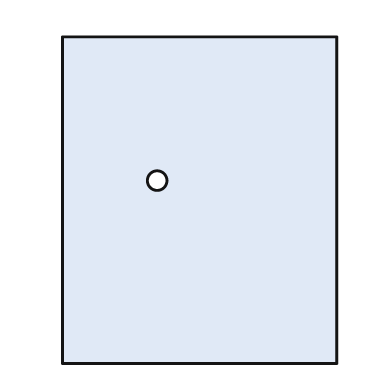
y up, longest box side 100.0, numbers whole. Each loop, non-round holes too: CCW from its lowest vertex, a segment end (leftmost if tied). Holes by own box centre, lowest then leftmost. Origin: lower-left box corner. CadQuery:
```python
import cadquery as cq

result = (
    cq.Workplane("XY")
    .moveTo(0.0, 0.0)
    .lineTo(84.0, 0.0)
    .lineTo(84.0, 100.0)
    .lineTo(0.0, 100.0)
    .close()
    .moveTo(29.0, 56.0)
    .circle(3.0)
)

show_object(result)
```